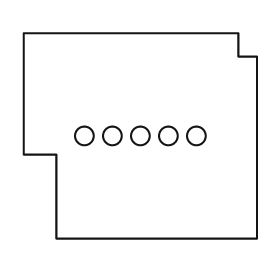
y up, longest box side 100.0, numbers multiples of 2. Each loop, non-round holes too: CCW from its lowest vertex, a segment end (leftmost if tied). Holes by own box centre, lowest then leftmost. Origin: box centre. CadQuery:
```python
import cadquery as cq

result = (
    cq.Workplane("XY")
    .moveTo(-36.0, -44.0)
    .lineTo(50.0, -44.0)
    .lineTo(50.0, 34.0)
    .lineTo(42.0, 34.0)
    .lineTo(42.0, 44.0)
    .lineTo(-50.0, 44.0)
    .lineTo(-50.0, -8.0)
    .lineTo(-36.0, -8.0)
    .close()
    .moveTo(-24.0, 0.0)
    .circle(4.0)
    .moveTo(-12.0, 0.0)
    .circle(4.0)
    .moveTo(0.0, 0.0)
    .circle(4.0)
    .moveTo(12.0, 0.0)
    .circle(4.0)
    .moveTo(24.0, 0.0)
    .circle(4.0)
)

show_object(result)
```